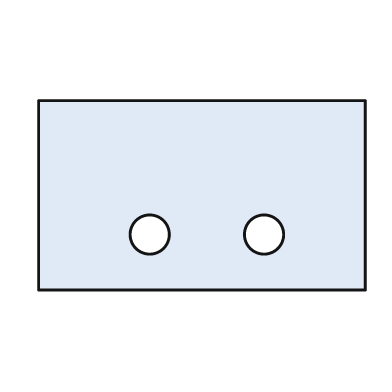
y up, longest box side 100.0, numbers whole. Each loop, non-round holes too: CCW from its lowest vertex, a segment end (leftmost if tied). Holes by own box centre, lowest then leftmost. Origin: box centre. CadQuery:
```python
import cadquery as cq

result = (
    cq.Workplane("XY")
    .moveTo(-50.0, -29.0)
    .lineTo(50.0, -29.0)
    .lineTo(50.0, 29.0)
    .lineTo(-50.0, 29.0)
    .close()
    .moveTo(-16.0, -12.0)
    .circle(6.0)
    .moveTo(19.0, -12.0)
    .circle(6.0)
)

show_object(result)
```